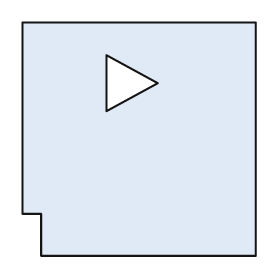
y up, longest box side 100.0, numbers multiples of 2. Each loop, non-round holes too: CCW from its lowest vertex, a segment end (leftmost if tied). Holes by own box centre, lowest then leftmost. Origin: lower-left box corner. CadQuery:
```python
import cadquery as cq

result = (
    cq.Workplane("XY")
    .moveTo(8.0, 0.0)
    .lineTo(100.0, 0.0)
    .lineTo(100.0, 100.0)
    .lineTo(0.0, 100.0)
    .lineTo(0.0, 18.0)
    .lineTo(8.0, 18.0)
    .close()
    .moveTo(36.0, 62.0)
    .lineTo(58.0, 74.0)
    .lineTo(36.0, 86.0)
    .close()
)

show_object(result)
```